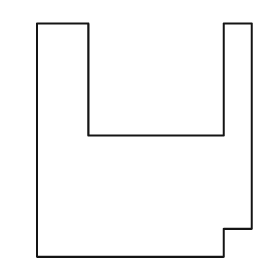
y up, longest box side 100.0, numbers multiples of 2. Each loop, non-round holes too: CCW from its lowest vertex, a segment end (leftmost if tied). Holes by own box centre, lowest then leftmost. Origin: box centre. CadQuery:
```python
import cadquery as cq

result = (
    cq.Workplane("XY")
    .moveTo(-46.0, -50.0)
    .lineTo(34.0, -50.0)
    .lineTo(34.0, -38.0)
    .lineTo(46.0, -38.0)
    .lineTo(46.0, 50.0)
    .lineTo(34.0, 50.0)
    .lineTo(34.0, 2.0)
    .lineTo(-24.0, 2.0)
    .lineTo(-24.0, 50.0)
    .lineTo(-46.0, 50.0)
    .close()
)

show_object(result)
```